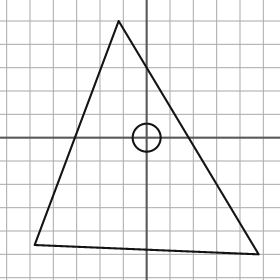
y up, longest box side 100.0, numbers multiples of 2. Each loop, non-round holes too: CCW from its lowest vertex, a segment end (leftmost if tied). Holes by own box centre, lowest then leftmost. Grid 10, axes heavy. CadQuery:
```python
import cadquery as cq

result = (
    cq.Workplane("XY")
    .moveTo(48.0, -50.0)
    .lineTo(-12.0, 50.0)
    .lineTo(-48.0, -46.0)
    .close()
    .moveTo(0.0, 0.0)
    .circle(6.0)
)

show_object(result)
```